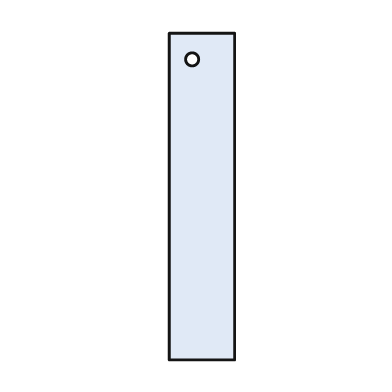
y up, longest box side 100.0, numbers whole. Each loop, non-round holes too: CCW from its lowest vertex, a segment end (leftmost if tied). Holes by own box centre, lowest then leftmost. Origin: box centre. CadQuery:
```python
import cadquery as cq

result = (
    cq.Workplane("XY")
    .moveTo(-10.0, -50.0)
    .lineTo(10.0, -50.0)
    .lineTo(10.0, 50.0)
    .lineTo(-10.0, 50.0)
    .close()
    .moveTo(-3.0, 42.0)
    .circle(2.0)
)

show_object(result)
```